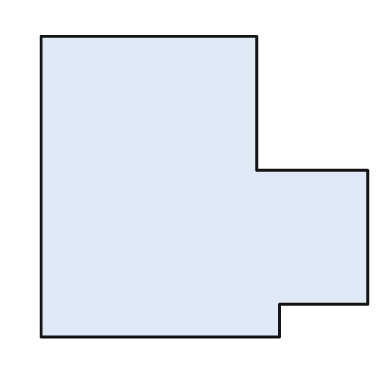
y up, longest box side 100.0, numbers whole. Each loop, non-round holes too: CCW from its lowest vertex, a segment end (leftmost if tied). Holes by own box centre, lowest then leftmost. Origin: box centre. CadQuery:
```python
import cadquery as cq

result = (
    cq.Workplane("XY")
    .moveTo(-50.0, -46.0)
    .lineTo(23.0, -46.0)
    .lineTo(23.0, -36.0)
    .lineTo(50.0, -36.0)
    .lineTo(50.0, 5.0)
    .lineTo(16.0, 5.0)
    .lineTo(16.0, 46.0)
    .lineTo(-50.0, 46.0)
    .close()
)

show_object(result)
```